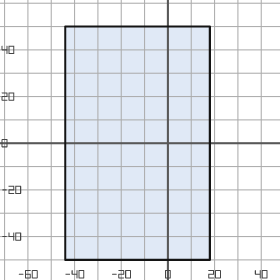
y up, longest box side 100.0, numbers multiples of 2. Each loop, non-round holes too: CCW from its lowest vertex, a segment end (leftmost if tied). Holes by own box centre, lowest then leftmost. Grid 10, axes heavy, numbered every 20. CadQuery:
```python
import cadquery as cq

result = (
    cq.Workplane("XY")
    .moveTo(-44.0, -50.0)
    .lineTo(18.0, -50.0)
    .lineTo(18.0, 50.0)
    .lineTo(-44.0, 50.0)
    .close()
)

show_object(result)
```